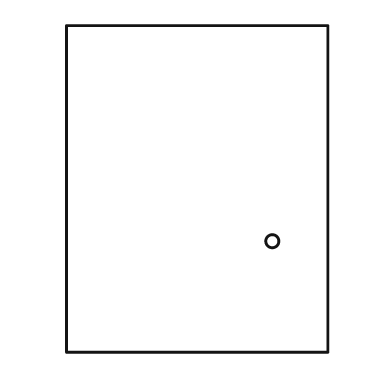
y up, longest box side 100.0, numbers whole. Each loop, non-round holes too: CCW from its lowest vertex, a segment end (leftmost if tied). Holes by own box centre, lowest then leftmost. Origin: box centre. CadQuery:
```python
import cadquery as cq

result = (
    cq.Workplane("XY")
    .moveTo(-40.0, -50.0)
    .lineTo(40.0, -50.0)
    .lineTo(40.0, 50.0)
    .lineTo(-40.0, 50.0)
    .close()
    .moveTo(23.0, -16.0)
    .circle(2.0)
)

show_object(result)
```